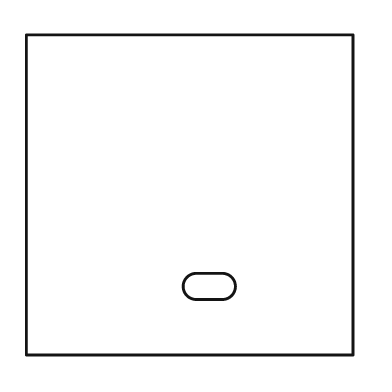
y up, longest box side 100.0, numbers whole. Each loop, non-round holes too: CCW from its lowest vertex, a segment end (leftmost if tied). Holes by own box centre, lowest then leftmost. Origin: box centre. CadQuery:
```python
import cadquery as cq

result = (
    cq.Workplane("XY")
    .moveTo(-50.0, -49.0)
    .lineTo(50.0, -49.0)
    .lineTo(50.0, 49.0)
    .lineTo(-50.0, 49.0)
    .close()
    .moveTo(2.0, -32.0)
    .lineTo(10.0, -32.0)
    .threePointArc((14.0, -28.0), (10.0, -24.0))
    .lineTo(2.0, -24.0)
    .threePointArc((-2.0, -28.0), (2.0, -32.0))
    .close()
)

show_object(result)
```